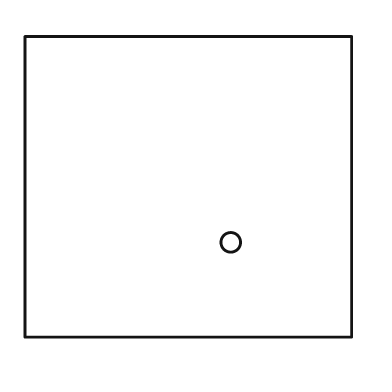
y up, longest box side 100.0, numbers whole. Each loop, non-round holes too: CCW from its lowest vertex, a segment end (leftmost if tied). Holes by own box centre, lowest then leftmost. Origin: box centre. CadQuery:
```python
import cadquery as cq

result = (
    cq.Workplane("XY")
    .moveTo(-50.0, -46.0)
    .lineTo(50.0, -46.0)
    .lineTo(50.0, 46.0)
    .lineTo(-50.0, 46.0)
    .close()
    .moveTo(13.0, -17.0)
    .circle(3.0)
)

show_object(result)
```